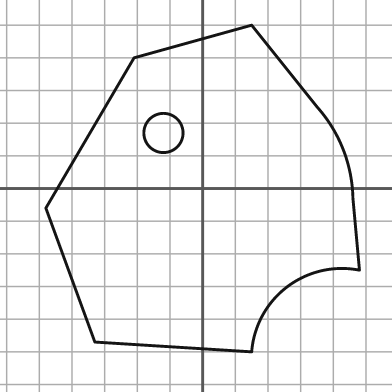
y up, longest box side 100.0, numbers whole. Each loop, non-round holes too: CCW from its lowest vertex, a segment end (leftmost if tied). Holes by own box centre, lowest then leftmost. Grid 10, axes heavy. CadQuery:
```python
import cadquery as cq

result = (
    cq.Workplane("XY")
    .moveTo(15.0, -50.0)
    .threePointArc((26.0, -30.0), (48.0, -25.0))
    .lineTo(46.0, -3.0)
    .threePointArc((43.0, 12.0), (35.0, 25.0))
    .lineTo(15.0, 50.0)
    .lineTo(-21.0, 40.0)
    .lineTo(-48.0, -6.0)
    .lineTo(-33.0, -47.0)
    .close()
    .moveTo(-12.0, 17.0)
    .circle(6.0)
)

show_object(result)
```